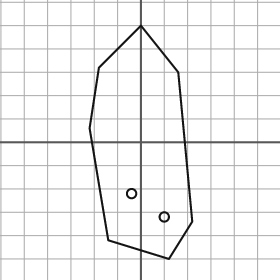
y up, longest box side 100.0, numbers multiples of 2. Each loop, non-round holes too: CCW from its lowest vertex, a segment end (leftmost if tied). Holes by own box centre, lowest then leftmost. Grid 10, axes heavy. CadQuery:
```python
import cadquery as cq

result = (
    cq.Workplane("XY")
    .moveTo(12.0, -50.0)
    .lineTo(22.0, -34.0)
    .lineTo(16.0, 30.0)
    .lineTo(0.0, 50.0)
    .lineTo(-18.0, 32.0)
    .lineTo(-22.0, 6.0)
    .lineTo(-14.0, -42.0)
    .close()
    .moveTo(10.0, -32.0)
    .circle(2.0)
    .moveTo(-4.0, -22.0)
    .circle(2.0)
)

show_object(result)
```